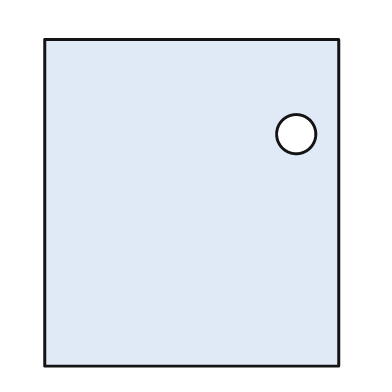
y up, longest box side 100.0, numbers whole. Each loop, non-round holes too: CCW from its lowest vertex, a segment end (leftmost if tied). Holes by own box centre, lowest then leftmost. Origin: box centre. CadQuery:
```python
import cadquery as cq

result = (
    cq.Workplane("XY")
    .moveTo(-45.0, -50.0)
    .lineTo(45.0, -50.0)
    .lineTo(45.0, 50.0)
    .lineTo(-45.0, 50.0)
    .close()
    .moveTo(32.0, 21.0)
    .circle(6.0)
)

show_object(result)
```